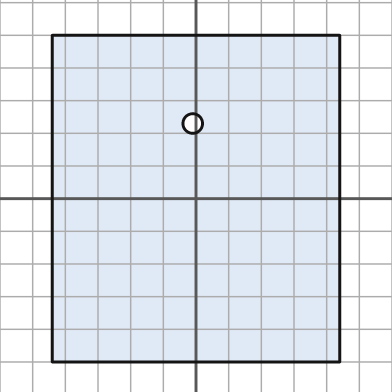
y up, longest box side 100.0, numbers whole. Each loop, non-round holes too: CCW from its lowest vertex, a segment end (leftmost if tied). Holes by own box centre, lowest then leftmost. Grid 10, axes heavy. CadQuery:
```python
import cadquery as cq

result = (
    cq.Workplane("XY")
    .moveTo(-44.0, -50.0)
    .lineTo(44.0, -50.0)
    .lineTo(44.0, 50.0)
    .lineTo(-44.0, 50.0)
    .close()
    .moveTo(-1.0, 23.0)
    .circle(3.0)
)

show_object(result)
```